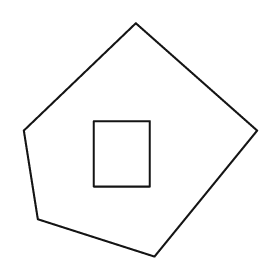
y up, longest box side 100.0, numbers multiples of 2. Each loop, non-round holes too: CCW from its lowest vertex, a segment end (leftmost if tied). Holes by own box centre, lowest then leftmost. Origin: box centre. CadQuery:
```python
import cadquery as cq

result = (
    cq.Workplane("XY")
    .moveTo(6.0, -50.0)
    .lineTo(50.0, 4.0)
    .lineTo(-2.0, 50.0)
    .lineTo(-50.0, 4.0)
    .lineTo(-44.0, -34.0)
    .close()
    .moveTo(-20.0, -20.0)
    .lineTo(4.0, -20.0)
    .lineTo(4.0, 8.0)
    .lineTo(-20.0, 8.0)
    .close()
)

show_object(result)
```